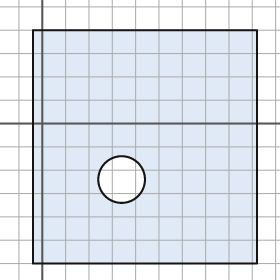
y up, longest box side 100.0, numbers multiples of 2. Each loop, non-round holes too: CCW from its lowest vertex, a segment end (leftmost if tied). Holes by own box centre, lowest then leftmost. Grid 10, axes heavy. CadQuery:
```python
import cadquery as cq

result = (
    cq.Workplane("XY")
    .moveTo(-4.0, -60.0)
    .lineTo(92.0, -60.0)
    .lineTo(92.0, 40.0)
    .lineTo(-4.0, 40.0)
    .close()
    .moveTo(34.0, -24.0)
    .circle(10.0)
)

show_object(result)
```